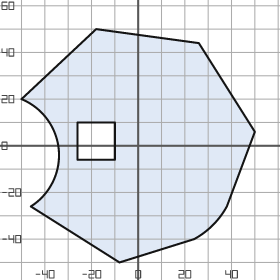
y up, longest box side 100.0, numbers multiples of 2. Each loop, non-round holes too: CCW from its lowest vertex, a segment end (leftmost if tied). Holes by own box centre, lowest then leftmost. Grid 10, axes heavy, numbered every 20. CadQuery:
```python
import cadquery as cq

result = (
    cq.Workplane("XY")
    .moveTo(-8.0, -50.0)
    .lineTo(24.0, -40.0)
    .threePointArc((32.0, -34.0), (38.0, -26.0))
    .lineTo(50.0, 6.0)
    .lineTo(26.0, 44.0)
    .lineTo(-18.0, 50.0)
    .lineTo(-50.0, 20.0)
    .threePointArc((-34.0, -2.0), (-46.0, -26.0))
    .close()
    .moveTo(-26.0, -6.0)
    .lineTo(-10.0, -6.0)
    .lineTo(-10.0, 10.0)
    .lineTo(-26.0, 10.0)
    .close()
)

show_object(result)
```